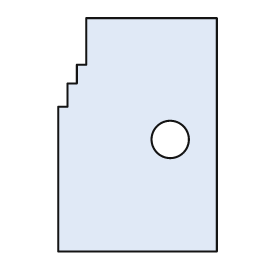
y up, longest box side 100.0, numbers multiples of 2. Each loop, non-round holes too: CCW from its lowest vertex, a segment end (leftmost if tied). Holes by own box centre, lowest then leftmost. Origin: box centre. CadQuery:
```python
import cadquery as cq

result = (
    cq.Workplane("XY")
    .moveTo(-34.0, -50.0)
    .lineTo(34.0, -50.0)
    .lineTo(34.0, 50.0)
    .lineTo(-22.0, 50.0)
    .lineTo(-22.0, 30.0)
    .lineTo(-26.0, 30.0)
    .lineTo(-26.0, 22.0)
    .lineTo(-30.0, 22.0)
    .lineTo(-30.0, 12.0)
    .lineTo(-34.0, 12.0)
    .close()
    .moveTo(14.0, -2.0)
    .circle(8.0)
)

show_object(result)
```